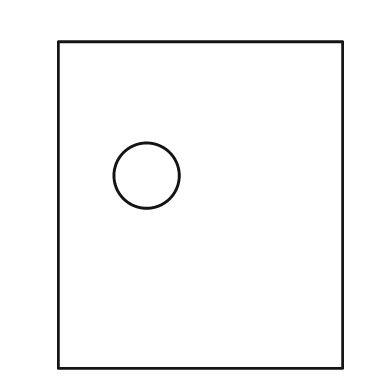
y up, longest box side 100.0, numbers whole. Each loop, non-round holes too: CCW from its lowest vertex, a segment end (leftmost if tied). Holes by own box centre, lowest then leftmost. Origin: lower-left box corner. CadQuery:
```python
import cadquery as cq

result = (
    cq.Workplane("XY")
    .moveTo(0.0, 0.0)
    .lineTo(87.0, 0.0)
    .lineTo(87.0, 100.0)
    .lineTo(0.0, 100.0)
    .close()
    .moveTo(27.0, 59.0)
    .circle(10.0)
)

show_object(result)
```